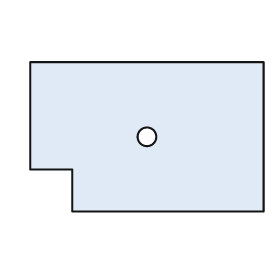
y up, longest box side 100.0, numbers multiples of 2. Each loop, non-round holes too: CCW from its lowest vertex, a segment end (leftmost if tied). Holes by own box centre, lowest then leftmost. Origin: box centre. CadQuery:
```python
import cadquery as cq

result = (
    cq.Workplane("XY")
    .moveTo(-32.0, -32.0)
    .lineTo(50.0, -32.0)
    .lineTo(50.0, 32.0)
    .lineTo(-50.0, 32.0)
    .lineTo(-50.0, -14.0)
    .lineTo(-32.0, -14.0)
    .close()
    .moveTo(0.0, 0.0)
    .circle(4.0)
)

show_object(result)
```